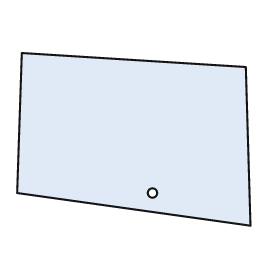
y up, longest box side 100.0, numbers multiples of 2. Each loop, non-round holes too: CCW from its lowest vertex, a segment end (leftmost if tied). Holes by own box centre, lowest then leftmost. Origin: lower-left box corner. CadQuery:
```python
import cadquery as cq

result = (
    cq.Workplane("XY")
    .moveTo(100.0, 0.0)
    .lineTo(98.0, 68.0)
    .lineTo(2.0, 74.0)
    .lineTo(0.0, 14.0)
    .close()
    .moveTo(58.0, 14.0)
    .circle(2.0)
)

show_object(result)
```